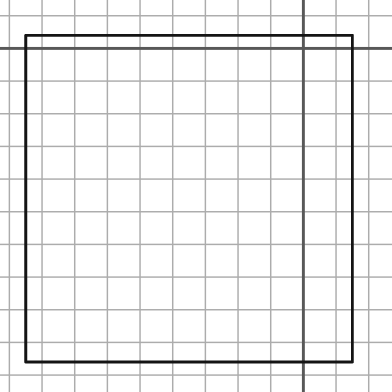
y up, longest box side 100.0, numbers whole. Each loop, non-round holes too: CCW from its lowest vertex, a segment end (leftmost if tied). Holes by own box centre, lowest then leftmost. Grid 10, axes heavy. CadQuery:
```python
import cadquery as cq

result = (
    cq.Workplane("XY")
    .moveTo(-85.0, -96.0)
    .lineTo(15.0, -96.0)
    .lineTo(15.0, 4.0)
    .lineTo(-85.0, 4.0)
    .close()
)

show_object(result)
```